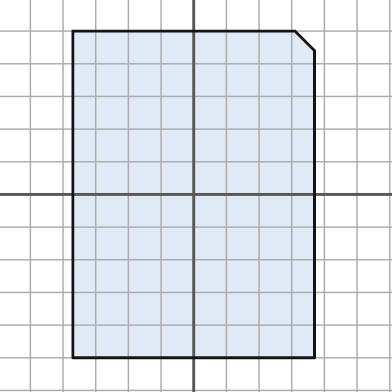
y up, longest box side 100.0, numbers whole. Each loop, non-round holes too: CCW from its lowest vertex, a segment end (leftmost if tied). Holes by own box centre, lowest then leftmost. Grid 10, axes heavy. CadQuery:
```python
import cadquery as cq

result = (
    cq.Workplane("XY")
    .moveTo(-37.0, -50.0)
    .lineTo(37.0, -50.0)
    .lineTo(37.0, 44.0)
    .lineTo(31.0, 50.0)
    .lineTo(-37.0, 50.0)
    .close()
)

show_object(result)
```